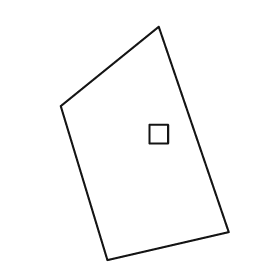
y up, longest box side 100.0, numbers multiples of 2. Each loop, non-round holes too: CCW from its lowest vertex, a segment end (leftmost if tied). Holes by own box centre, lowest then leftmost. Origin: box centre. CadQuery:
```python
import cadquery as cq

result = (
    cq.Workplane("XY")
    .moveTo(-16.0, -50.0)
    .lineTo(36.0, -38.0)
    .lineTo(6.0, 50.0)
    .lineTo(-36.0, 16.0)
    .close()
    .moveTo(2.0, 0.0)
    .lineTo(10.0, 0.0)
    .lineTo(10.0, 8.0)
    .lineTo(2.0, 8.0)
    .close()
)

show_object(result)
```